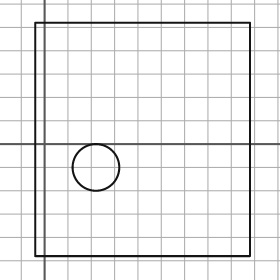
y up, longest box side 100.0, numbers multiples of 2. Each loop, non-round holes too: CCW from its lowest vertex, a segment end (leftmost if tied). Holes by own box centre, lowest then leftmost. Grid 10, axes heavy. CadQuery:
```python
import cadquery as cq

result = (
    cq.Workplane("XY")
    .moveTo(-4.0, -48.0)
    .lineTo(88.0, -48.0)
    .lineTo(88.0, 52.0)
    .lineTo(-4.0, 52.0)
    .close()
    .moveTo(22.0, -10.0)
    .circle(10.0)
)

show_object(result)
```